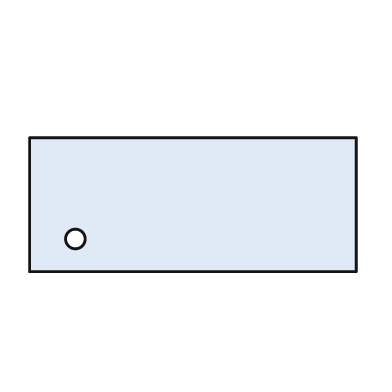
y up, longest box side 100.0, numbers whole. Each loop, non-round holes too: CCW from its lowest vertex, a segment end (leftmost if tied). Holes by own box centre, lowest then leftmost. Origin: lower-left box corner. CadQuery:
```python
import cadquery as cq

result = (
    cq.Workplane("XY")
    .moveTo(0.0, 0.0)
    .lineTo(100.0, 0.0)
    .lineTo(100.0, 41.0)
    .lineTo(0.0, 41.0)
    .close()
    .moveTo(14.0, 10.0)
    .circle(3.0)
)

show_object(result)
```